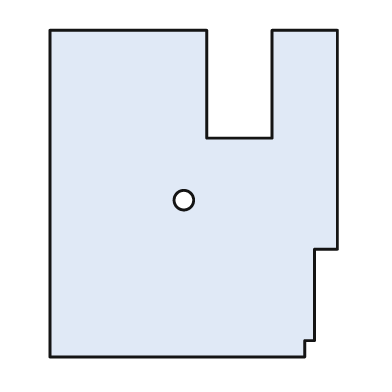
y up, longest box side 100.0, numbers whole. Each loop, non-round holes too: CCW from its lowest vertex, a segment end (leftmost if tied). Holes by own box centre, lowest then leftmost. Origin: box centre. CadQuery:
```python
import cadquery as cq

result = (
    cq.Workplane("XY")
    .moveTo(-44.0, -50.0)
    .lineTo(34.0, -50.0)
    .lineTo(34.0, -45.0)
    .lineTo(37.0, -45.0)
    .lineTo(37.0, -17.0)
    .lineTo(44.0, -17.0)
    .lineTo(44.0, 50.0)
    .lineTo(24.0, 50.0)
    .lineTo(24.0, 17.0)
    .lineTo(4.0, 17.0)
    .lineTo(4.0, 50.0)
    .lineTo(-44.0, 50.0)
    .close()
    .moveTo(-3.0, -2.0)
    .circle(3.0)
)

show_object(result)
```